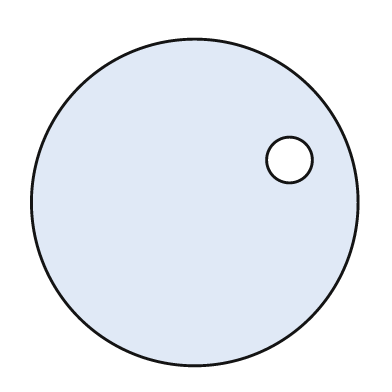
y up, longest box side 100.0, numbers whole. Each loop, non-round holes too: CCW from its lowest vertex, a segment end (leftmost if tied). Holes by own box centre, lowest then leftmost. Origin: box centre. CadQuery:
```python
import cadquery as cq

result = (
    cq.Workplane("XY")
    .moveTo(0.0, 0.0)
    .circle(50.0)
    .moveTo(29.0, 13.0)
    .circle(7.0)
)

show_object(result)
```